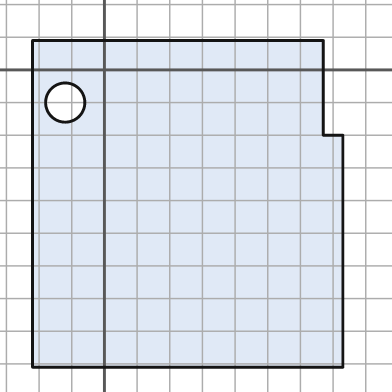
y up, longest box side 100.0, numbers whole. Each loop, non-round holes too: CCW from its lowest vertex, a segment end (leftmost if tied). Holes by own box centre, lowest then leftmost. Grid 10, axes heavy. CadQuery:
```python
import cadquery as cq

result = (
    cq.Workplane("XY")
    .moveTo(-22.0, -91.0)
    .lineTo(73.0, -91.0)
    .lineTo(73.0, -20.0)
    .lineTo(67.0, -20.0)
    .lineTo(67.0, 9.0)
    .lineTo(-22.0, 9.0)
    .close()
    .moveTo(-12.0, -10.0)
    .circle(6.0)
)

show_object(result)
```